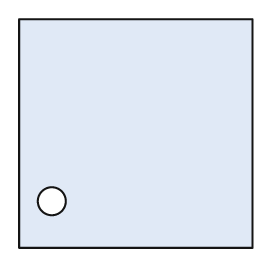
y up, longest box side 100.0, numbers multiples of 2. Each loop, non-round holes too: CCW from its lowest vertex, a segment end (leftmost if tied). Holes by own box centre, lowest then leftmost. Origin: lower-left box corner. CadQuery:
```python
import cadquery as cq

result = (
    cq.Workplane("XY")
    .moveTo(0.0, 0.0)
    .lineTo(100.0, 0.0)
    .lineTo(100.0, 98.0)
    .lineTo(0.0, 98.0)
    .close()
    .moveTo(14.0, 20.0)
    .circle(6.0)
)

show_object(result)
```